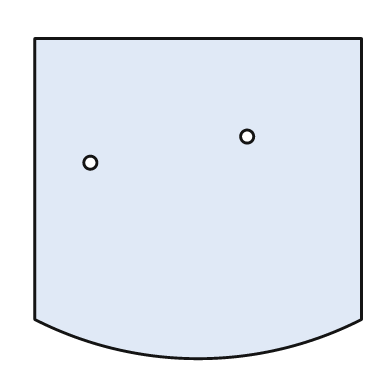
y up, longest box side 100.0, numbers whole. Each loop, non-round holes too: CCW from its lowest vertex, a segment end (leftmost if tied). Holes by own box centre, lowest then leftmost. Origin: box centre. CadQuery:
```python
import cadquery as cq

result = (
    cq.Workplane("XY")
    .moveTo(-50.0, -37.0)
    .threePointArc((0.0, -49.0), (50.0, -37.0))
    .lineTo(50.0, 49.0)
    .lineTo(-50.0, 49.0)
    .close()
    .moveTo(-33.0, 11.0)
    .circle(2.0)
    .moveTo(15.0, 19.0)
    .circle(2.0)
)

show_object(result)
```